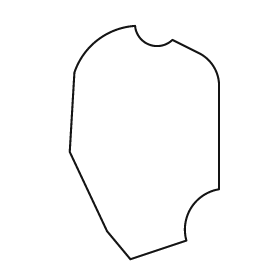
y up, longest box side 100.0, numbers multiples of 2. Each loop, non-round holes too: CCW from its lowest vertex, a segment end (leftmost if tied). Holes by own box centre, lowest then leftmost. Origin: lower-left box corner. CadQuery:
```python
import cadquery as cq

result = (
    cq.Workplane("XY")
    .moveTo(26.0, 0.0)
    .lineTo(50.0, 8.0)
    .threePointArc((52.0, 22.0), (64.0, 30.0))
    .lineTo(64.0, 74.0)
    .threePointArc((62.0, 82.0), (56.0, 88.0))
    .lineTo(44.0, 94.0)
    .threePointArc((34.0, 92.0), (28.0, 100.0))
    .threePointArc((12.0, 94.0), (2.0, 80.0))
    .lineTo(0.0, 46.0)
    .lineTo(16.0, 12.0)
    .close()
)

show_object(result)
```